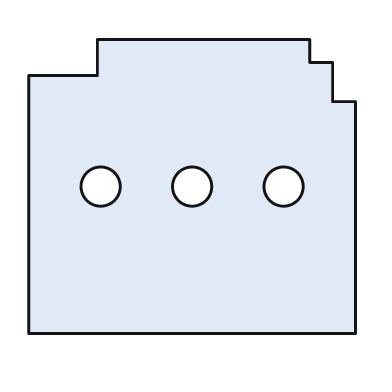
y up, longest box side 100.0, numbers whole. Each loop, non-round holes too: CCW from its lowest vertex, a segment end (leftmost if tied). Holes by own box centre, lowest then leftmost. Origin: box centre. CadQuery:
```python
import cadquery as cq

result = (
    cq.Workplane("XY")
    .moveTo(-50.0, -45.0)
    .lineTo(50.0, -45.0)
    .lineTo(50.0, 26.0)
    .lineTo(43.0, 26.0)
    .lineTo(43.0, 38.0)
    .lineTo(36.0, 38.0)
    .lineTo(36.0, 45.0)
    .lineTo(-29.0, 45.0)
    .lineTo(-29.0, 34.0)
    .lineTo(-50.0, 34.0)
    .close()
    .moveTo(-28.0, 0.0)
    .circle(6.0)
    .moveTo(0.0, 0.0)
    .circle(6.0)
    .moveTo(28.0, 0.0)
    .circle(6.0)
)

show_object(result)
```